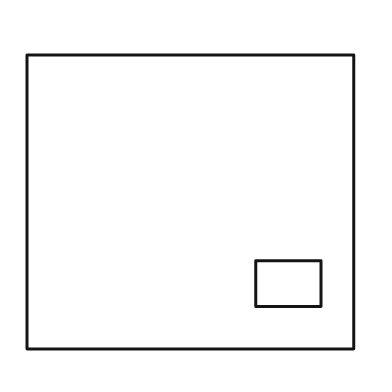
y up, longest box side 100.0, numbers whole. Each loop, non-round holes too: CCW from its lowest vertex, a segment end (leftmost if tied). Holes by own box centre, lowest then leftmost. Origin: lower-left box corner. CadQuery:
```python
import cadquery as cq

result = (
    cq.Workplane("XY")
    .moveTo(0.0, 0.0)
    .lineTo(100.0, 0.0)
    .lineTo(100.0, 90.0)
    .lineTo(0.0, 90.0)
    .close()
    .moveTo(70.0, 13.0)
    .lineTo(90.0, 13.0)
    .lineTo(90.0, 27.0)
    .lineTo(70.0, 27.0)
    .close()
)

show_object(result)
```